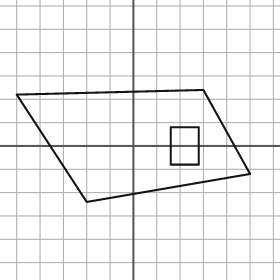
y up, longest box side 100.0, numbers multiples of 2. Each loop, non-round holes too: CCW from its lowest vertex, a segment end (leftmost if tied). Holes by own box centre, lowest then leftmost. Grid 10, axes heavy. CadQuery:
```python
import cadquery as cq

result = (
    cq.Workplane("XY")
    .moveTo(-20.0, -24.0)
    .lineTo(50.0, -12.0)
    .lineTo(30.0, 24.0)
    .lineTo(-50.0, 22.0)
    .close()
    .moveTo(16.0, -8.0)
    .lineTo(28.0, -8.0)
    .lineTo(28.0, 8.0)
    .lineTo(16.0, 8.0)
    .close()
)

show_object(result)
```